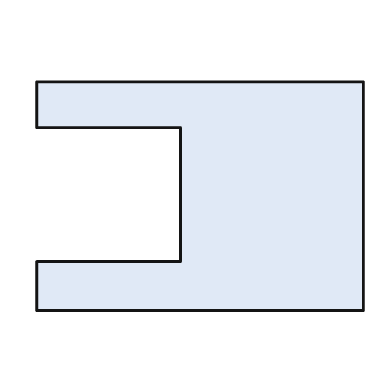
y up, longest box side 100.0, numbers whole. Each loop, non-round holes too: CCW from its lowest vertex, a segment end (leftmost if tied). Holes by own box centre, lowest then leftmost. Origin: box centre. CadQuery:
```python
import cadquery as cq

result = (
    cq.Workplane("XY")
    .moveTo(-50.0, -35.0)
    .lineTo(50.0, -35.0)
    .lineTo(50.0, 35.0)
    .lineTo(-50.0, 35.0)
    .lineTo(-50.0, 21.0)
    .lineTo(-6.0, 21.0)
    .lineTo(-6.0, -20.0)
    .lineTo(-50.0, -20.0)
    .close()
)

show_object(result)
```